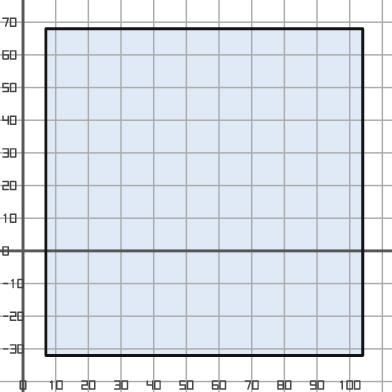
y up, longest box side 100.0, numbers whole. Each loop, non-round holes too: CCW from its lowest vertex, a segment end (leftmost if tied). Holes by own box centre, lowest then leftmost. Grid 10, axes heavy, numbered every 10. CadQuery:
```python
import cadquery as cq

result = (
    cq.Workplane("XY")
    .moveTo(7.0, -32.0)
    .lineTo(104.0, -32.0)
    .lineTo(104.0, 68.0)
    .lineTo(7.0, 68.0)
    .close()
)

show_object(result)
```